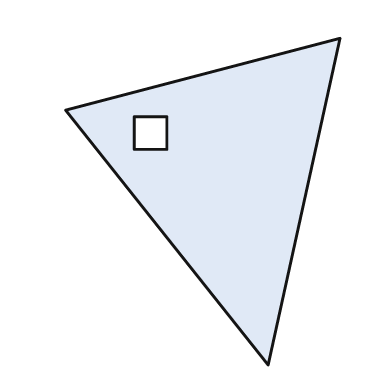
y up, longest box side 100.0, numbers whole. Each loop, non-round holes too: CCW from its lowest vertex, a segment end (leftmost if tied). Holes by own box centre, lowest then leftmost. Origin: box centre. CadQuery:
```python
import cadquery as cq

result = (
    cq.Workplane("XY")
    .moveTo(20.0, -50.0)
    .lineTo(42.0, 50.0)
    .lineTo(-42.0, 28.0)
    .close()
    .moveTo(-21.0, 16.0)
    .lineTo(-11.0, 16.0)
    .lineTo(-11.0, 26.0)
    .lineTo(-21.0, 26.0)
    .close()
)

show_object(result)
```